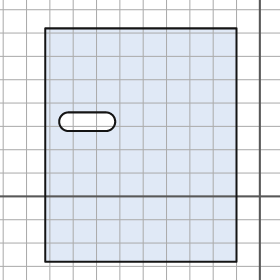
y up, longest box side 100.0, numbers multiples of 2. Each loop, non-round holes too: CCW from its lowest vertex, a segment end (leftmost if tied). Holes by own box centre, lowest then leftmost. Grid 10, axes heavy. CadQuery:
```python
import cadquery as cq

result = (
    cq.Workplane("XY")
    .moveTo(-92.0, -28.0)
    .lineTo(-10.0, -28.0)
    .lineTo(-10.0, 72.0)
    .lineTo(-92.0, 72.0)
    .close()
    .moveTo(-82.0, 28.0)
    .lineTo(-66.0, 28.0)
    .threePointArc((-62.0, 32.0), (-66.0, 36.0))
    .lineTo(-82.0, 36.0)
    .threePointArc((-86.0, 32.0), (-82.0, 28.0))
    .close()
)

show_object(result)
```